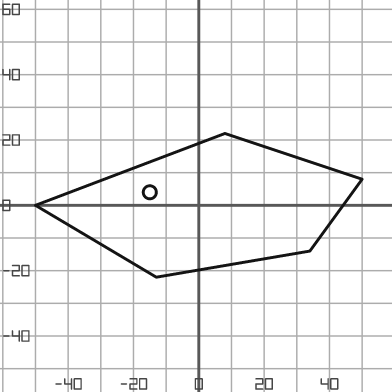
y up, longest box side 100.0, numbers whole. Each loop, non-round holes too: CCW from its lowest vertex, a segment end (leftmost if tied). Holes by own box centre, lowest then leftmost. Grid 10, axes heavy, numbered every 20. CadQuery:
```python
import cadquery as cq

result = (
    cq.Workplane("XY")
    .moveTo(-13.0, -22.0)
    .lineTo(34.0, -14.0)
    .lineTo(50.0, 8.0)
    .lineTo(8.0, 22.0)
    .lineTo(-50.0, 0.0)
    .close()
    .moveTo(-15.0, 4.0)
    .circle(2.0)
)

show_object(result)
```